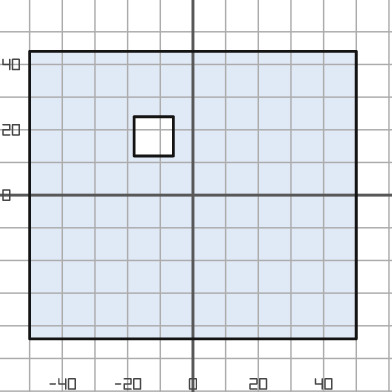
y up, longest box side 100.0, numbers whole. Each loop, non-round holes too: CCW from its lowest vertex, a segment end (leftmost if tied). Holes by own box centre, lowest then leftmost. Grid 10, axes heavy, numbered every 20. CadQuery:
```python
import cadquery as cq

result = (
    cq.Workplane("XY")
    .moveTo(-50.0, -44.0)
    .lineTo(50.0, -44.0)
    .lineTo(50.0, 44.0)
    .lineTo(-50.0, 44.0)
    .close()
    .moveTo(-18.0, 12.0)
    .lineTo(-6.0, 12.0)
    .lineTo(-6.0, 24.0)
    .lineTo(-18.0, 24.0)
    .close()
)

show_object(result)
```